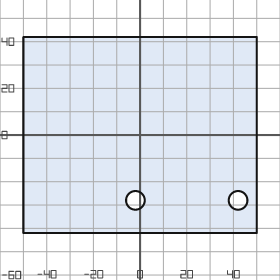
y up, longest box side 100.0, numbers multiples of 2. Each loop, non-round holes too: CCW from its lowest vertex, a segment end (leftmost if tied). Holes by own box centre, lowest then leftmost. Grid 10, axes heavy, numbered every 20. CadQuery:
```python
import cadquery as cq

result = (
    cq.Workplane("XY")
    .moveTo(-50.0, -42.0)
    .lineTo(50.0, -42.0)
    .lineTo(50.0, 42.0)
    .lineTo(-50.0, 42.0)
    .close()
    .moveTo(-2.0, -28.0)
    .circle(4.0)
    .moveTo(42.0, -28.0)
    .circle(4.0)
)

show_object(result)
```